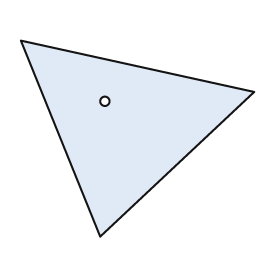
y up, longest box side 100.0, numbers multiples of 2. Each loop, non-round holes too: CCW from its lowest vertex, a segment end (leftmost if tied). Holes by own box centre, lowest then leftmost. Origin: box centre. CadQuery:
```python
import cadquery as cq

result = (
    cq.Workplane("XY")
    .moveTo(-16.0, -42.0)
    .lineTo(50.0, 20.0)
    .lineTo(-50.0, 42.0)
    .close()
    .moveTo(-14.0, 16.0)
    .circle(2.0)
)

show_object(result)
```